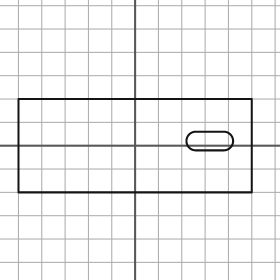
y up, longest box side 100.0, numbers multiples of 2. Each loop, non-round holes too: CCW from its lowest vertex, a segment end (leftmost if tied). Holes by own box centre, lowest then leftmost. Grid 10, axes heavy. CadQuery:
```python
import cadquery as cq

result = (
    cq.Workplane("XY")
    .moveTo(-50.0, -20.0)
    .lineTo(50.0, -20.0)
    .lineTo(50.0, 20.0)
    .lineTo(-50.0, 20.0)
    .close()
    .moveTo(26.0, -2.0)
    .lineTo(38.0, -2.0)
    .threePointArc((42.0, 2.0), (38.0, 6.0))
    .lineTo(26.0, 6.0)
    .threePointArc((22.0, 2.0), (26.0, -2.0))
    .close()
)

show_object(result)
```